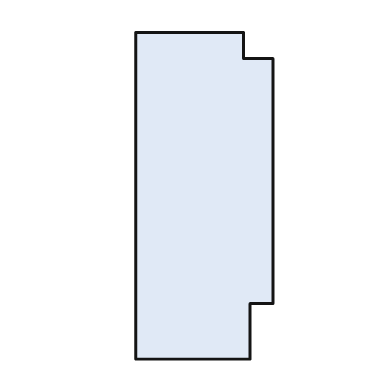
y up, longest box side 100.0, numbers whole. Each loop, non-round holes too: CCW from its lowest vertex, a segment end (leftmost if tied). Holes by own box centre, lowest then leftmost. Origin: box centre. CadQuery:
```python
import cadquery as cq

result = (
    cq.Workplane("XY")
    .moveTo(-21.0, -50.0)
    .lineTo(14.0, -50.0)
    .lineTo(14.0, -33.0)
    .lineTo(21.0, -33.0)
    .lineTo(21.0, 42.0)
    .lineTo(12.0, 42.0)
    .lineTo(12.0, 50.0)
    .lineTo(-21.0, 50.0)
    .close()
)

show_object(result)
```